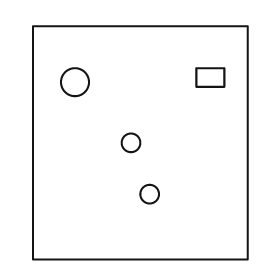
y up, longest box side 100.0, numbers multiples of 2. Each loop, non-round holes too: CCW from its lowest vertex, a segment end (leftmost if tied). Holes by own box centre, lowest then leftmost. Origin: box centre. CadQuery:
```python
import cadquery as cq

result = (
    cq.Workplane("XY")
    .moveTo(-46.0, -50.0)
    .lineTo(46.0, -50.0)
    .lineTo(46.0, 50.0)
    .lineTo(-46.0, 50.0)
    .close()
    .moveTo(4.0, -22.0)
    .circle(4.0)
    .moveTo(-4.0, 0.0)
    .circle(4.0)
    .moveTo(-28.0, 26.0)
    .circle(6.0)
    .moveTo(24.0, 24.0)
    .lineTo(36.0, 24.0)
    .lineTo(36.0, 32.0)
    .lineTo(24.0, 32.0)
    .close()
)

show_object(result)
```